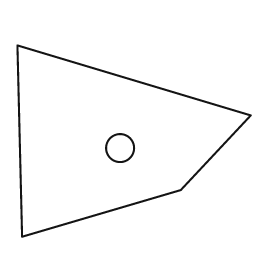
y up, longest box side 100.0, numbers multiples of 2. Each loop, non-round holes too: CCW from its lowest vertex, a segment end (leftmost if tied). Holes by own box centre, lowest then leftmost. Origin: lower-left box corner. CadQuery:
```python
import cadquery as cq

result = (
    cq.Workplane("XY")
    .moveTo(2.0, 0.0)
    .lineTo(70.0, 20.0)
    .lineTo(100.0, 52.0)
    .lineTo(0.0, 82.0)
    .close()
    .moveTo(44.0, 38.0)
    .circle(6.0)
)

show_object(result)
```